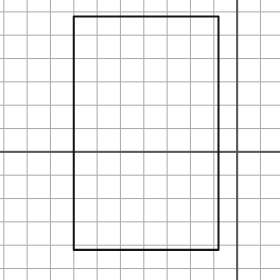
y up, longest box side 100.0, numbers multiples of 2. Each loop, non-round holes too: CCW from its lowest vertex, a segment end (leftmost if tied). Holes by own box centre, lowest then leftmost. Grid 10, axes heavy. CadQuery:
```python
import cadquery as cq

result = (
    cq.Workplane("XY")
    .moveTo(-70.0, -42.0)
    .lineTo(-8.0, -42.0)
    .lineTo(-8.0, 58.0)
    .lineTo(-70.0, 58.0)
    .close()
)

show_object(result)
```